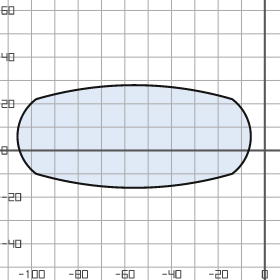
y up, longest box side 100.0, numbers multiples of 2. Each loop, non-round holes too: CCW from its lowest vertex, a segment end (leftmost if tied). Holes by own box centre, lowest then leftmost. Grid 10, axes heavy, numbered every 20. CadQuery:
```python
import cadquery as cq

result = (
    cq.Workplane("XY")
    .moveTo(-98.0, -10.0)
    .threePointArc((-56.0, -16.0), (-14.0, -10.0))
    .threePointArc((-6.0, 6.0), (-14.0, 22.0))
    .threePointArc((-56.0, 28.0), (-98.0, 22.0))
    .threePointArc((-106.0, 6.0), (-98.0, -10.0))
    .close()
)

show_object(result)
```